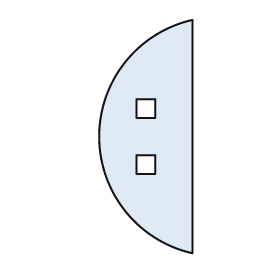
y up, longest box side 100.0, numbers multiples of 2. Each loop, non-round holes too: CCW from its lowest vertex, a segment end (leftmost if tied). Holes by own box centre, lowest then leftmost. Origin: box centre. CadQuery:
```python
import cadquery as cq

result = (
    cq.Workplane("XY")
    .moveTo(20.0, -50.0)
    .lineTo(20.0, 50.0)
    .threePointArc((-20.0, 0.0), (20.0, -50.0))
    .close()
    .moveTo(-4.0, -16.0)
    .lineTo(4.0, -16.0)
    .lineTo(4.0, -8.0)
    .lineTo(-4.0, -8.0)
    .close()
    .moveTo(-4.0, 8.0)
    .lineTo(4.0, 8.0)
    .lineTo(4.0, 16.0)
    .lineTo(-4.0, 16.0)
    .close()
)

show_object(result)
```